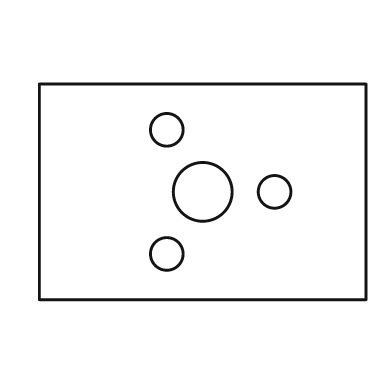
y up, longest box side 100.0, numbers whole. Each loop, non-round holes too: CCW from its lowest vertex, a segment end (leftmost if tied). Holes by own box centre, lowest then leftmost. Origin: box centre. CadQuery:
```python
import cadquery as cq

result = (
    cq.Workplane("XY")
    .moveTo(-50.0, -33.0)
    .lineTo(50.0, -33.0)
    .lineTo(50.0, 33.0)
    .lineTo(-50.0, 33.0)
    .close()
    .moveTo(-11.0, -19.0)
    .circle(5.0)
    .moveTo(0.0, 0.0)
    .circle(9.0)
    .moveTo(22.0, 0.0)
    .circle(5.0)
    .moveTo(-11.0, 19.0)
    .circle(5.0)
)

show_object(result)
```